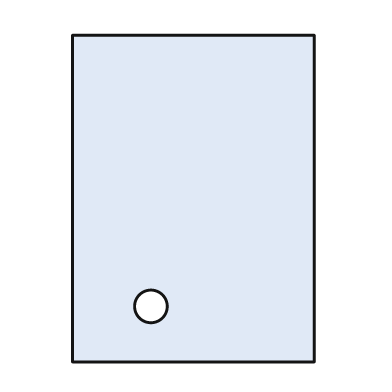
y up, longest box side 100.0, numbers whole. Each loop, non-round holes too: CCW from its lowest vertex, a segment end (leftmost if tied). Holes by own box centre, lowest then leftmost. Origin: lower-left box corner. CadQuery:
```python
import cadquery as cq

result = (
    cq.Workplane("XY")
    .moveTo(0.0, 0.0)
    .lineTo(74.0, 0.0)
    .lineTo(74.0, 100.0)
    .lineTo(0.0, 100.0)
    .close()
    .moveTo(24.0, 17.0)
    .circle(5.0)
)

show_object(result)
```